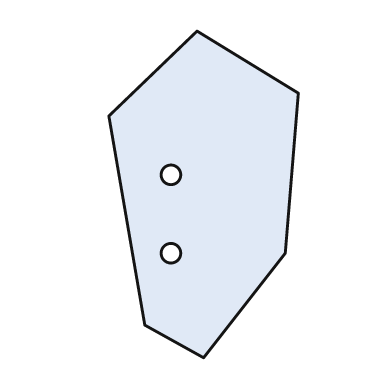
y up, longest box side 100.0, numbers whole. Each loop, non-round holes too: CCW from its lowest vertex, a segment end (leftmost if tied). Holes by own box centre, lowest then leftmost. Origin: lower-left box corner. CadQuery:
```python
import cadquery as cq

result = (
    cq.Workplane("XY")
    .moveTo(29.0, 0.0)
    .lineTo(54.0, 32.0)
    .lineTo(58.0, 81.0)
    .lineTo(27.0, 100.0)
    .lineTo(0.0, 74.0)
    .lineTo(11.0, 10.0)
    .close()
    .moveTo(19.0, 32.0)
    .circle(3.0)
    .moveTo(19.0, 56.0)
    .circle(3.0)
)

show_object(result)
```